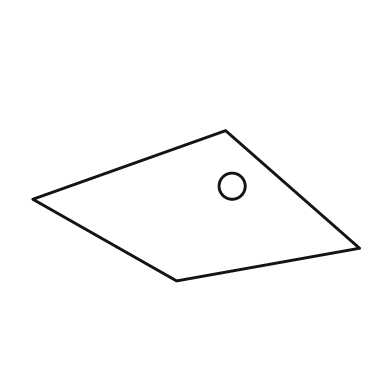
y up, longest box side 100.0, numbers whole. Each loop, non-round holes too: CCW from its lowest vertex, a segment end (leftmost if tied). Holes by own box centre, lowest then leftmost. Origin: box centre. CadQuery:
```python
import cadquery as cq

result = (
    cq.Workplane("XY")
    .moveTo(-6.0, -23.0)
    .lineTo(50.0, -13.0)
    .lineTo(9.0, 23.0)
    .lineTo(-50.0, 2.0)
    .close()
    .moveTo(11.0, 6.0)
    .circle(4.0)
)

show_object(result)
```